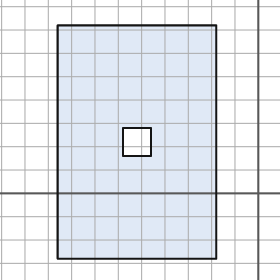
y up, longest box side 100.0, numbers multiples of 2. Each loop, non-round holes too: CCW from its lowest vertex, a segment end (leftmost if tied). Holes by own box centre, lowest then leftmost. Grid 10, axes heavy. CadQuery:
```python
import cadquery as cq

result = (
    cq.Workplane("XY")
    .moveTo(-86.0, -28.0)
    .lineTo(-18.0, -28.0)
    .lineTo(-18.0, 72.0)
    .lineTo(-86.0, 72.0)
    .close()
    .moveTo(-58.0, 16.0)
    .lineTo(-46.0, 16.0)
    .lineTo(-46.0, 28.0)
    .lineTo(-58.0, 28.0)
    .close()
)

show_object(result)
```